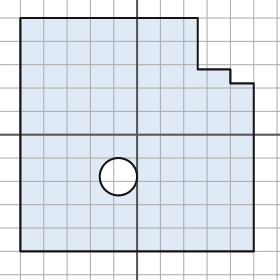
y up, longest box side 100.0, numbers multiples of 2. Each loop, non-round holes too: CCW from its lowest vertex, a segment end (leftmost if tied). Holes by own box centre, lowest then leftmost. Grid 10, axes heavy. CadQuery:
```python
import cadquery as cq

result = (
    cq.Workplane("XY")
    .moveTo(-50.0, -50.0)
    .lineTo(50.0, -50.0)
    .lineTo(50.0, 22.0)
    .lineTo(40.0, 22.0)
    .lineTo(40.0, 28.0)
    .lineTo(26.0, 28.0)
    .lineTo(26.0, 50.0)
    .lineTo(-50.0, 50.0)
    .close()
    .moveTo(-8.0, -18.0)
    .circle(8.0)
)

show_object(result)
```